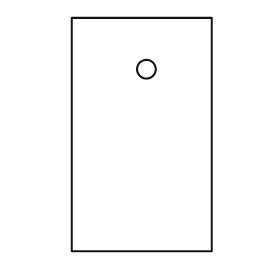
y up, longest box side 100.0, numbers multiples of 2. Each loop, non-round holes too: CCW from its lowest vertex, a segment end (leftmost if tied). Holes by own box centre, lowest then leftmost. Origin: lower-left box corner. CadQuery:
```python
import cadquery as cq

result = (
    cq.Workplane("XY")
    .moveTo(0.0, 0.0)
    .lineTo(60.0, 0.0)
    .lineTo(60.0, 100.0)
    .lineTo(0.0, 100.0)
    .close()
    .moveTo(32.0, 78.0)
    .circle(4.0)
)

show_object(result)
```